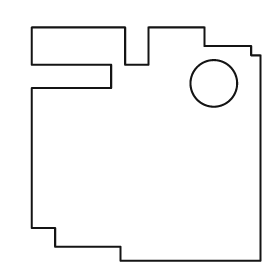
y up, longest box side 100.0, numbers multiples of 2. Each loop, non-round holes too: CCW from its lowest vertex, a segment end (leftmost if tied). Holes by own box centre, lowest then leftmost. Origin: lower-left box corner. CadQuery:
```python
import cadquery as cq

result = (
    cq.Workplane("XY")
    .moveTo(38.0, 0.0)
    .lineTo(98.0, 0.0)
    .lineTo(98.0, 88.0)
    .lineTo(94.0, 88.0)
    .lineTo(94.0, 92.0)
    .lineTo(74.0, 92.0)
    .lineTo(74.0, 100.0)
    .lineTo(50.0, 100.0)
    .lineTo(50.0, 84.0)
    .lineTo(40.0, 84.0)
    .lineTo(40.0, 100.0)
    .lineTo(0.0, 100.0)
    .lineTo(0.0, 84.0)
    .lineTo(34.0, 84.0)
    .lineTo(34.0, 74.0)
    .lineTo(0.0, 74.0)
    .lineTo(0.0, 14.0)
    .lineTo(10.0, 14.0)
    .lineTo(10.0, 6.0)
    .lineTo(38.0, 6.0)
    .close()
    .moveTo(78.0, 76.0)
    .circle(10.0)
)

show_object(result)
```